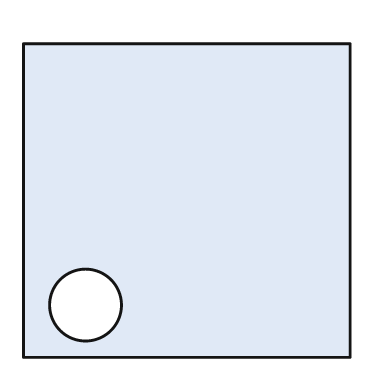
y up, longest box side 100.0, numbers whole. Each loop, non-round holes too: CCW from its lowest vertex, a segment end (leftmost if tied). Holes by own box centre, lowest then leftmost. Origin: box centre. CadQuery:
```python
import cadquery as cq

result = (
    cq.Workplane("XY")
    .moveTo(-50.0, -48.0)
    .lineTo(50.0, -48.0)
    .lineTo(50.0, 48.0)
    .lineTo(-50.0, 48.0)
    .close()
    .moveTo(-31.0, -32.0)
    .circle(11.0)
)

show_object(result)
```